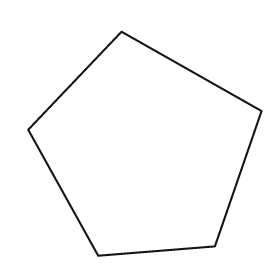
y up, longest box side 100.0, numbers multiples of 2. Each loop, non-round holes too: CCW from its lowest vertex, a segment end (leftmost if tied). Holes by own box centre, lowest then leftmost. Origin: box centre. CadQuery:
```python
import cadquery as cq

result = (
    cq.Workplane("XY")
    .moveTo(-20.0, -48.0)
    .lineTo(30.0, -44.0)
    .lineTo(50.0, 14.0)
    .lineTo(-10.0, 48.0)
    .lineTo(-50.0, 6.0)
    .close()
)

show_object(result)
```